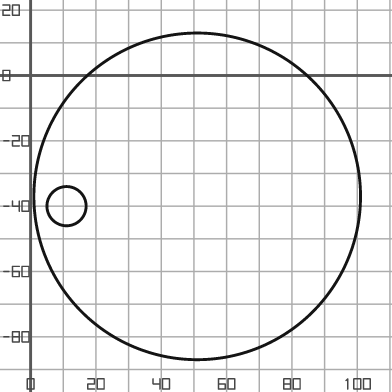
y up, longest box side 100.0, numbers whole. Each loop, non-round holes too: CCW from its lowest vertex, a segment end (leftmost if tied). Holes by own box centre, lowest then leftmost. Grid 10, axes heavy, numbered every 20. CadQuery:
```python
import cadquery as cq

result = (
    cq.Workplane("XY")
    .moveTo(51.0, -37.0)
    .circle(50.0)
    .moveTo(11.0, -40.0)
    .circle(6.0)
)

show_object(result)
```